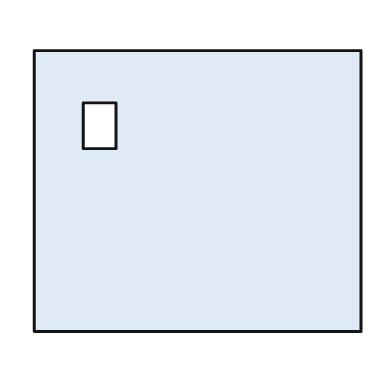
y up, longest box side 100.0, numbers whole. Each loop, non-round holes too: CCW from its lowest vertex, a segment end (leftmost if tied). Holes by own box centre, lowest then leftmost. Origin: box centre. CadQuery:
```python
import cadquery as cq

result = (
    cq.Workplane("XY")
    .moveTo(-50.0, -43.0)
    .lineTo(50.0, -43.0)
    .lineTo(50.0, 43.0)
    .lineTo(-50.0, 43.0)
    .close()
    .moveTo(-35.0, 13.0)
    .lineTo(-25.0, 13.0)
    .lineTo(-25.0, 27.0)
    .lineTo(-35.0, 27.0)
    .close()
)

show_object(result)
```